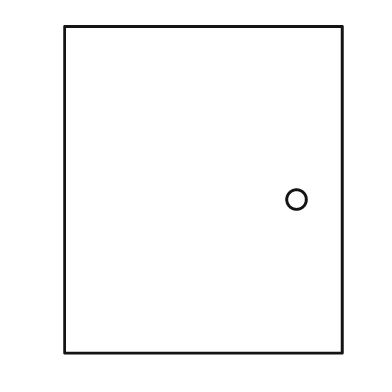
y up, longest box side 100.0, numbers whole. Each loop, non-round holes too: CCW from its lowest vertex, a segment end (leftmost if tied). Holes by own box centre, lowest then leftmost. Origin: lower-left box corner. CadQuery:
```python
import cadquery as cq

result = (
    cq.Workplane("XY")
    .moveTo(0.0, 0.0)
    .lineTo(85.0, 0.0)
    .lineTo(85.0, 100.0)
    .lineTo(0.0, 100.0)
    .close()
    .moveTo(71.0, 47.0)
    .circle(3.0)
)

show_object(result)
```